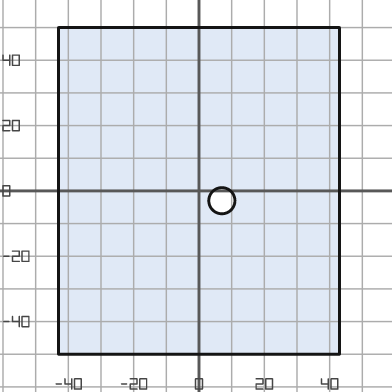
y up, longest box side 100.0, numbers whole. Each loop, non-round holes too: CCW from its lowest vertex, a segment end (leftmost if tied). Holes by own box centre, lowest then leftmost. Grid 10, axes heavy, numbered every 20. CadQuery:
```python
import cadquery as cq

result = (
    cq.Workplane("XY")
    .moveTo(-43.0, -50.0)
    .lineTo(43.0, -50.0)
    .lineTo(43.0, 50.0)
    .lineTo(-43.0, 50.0)
    .close()
    .moveTo(7.0, -3.0)
    .circle(4.0)
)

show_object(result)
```